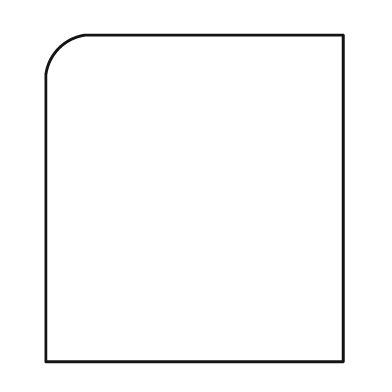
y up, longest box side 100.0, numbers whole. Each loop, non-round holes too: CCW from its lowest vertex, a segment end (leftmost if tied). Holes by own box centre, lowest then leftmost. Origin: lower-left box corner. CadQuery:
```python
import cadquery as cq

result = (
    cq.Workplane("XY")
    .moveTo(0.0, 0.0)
    .lineTo(91.0, 0.0)
    .lineTo(91.0, 100.0)
    .lineTo(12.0, 100.0)
    .threePointArc((4.0, 96.0), (0.0, 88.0))
    .close()
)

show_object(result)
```